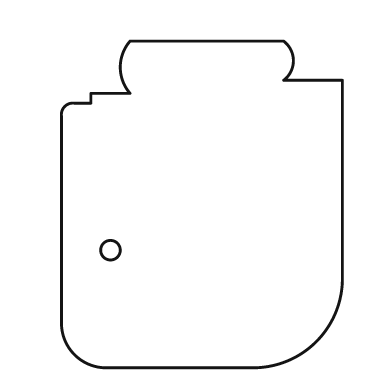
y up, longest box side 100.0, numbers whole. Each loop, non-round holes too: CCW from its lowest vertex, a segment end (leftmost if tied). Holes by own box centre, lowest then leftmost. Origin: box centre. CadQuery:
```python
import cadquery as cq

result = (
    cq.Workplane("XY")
    .moveTo(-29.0, -50.0)
    .lineTo(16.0, -50.0)
    .threePointArc((35.0, -42.0), (43.0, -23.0))
    .lineTo(43.0, 38.0)
    .lineTo(25.0, 38.0)
    .threePointArc((28.0, 44.0), (25.0, 50.0))
    .lineTo(-22.0, 50.0)
    .threePointArc((-25.0, 42.0), (-22.0, 34.0))
    .lineTo(-34.0, 34.0)
    .lineTo(-34.0, 31.0)
    .lineTo(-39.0, 31.0)
    .threePointArc((-42.0, 30.0), (-43.0, 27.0))
    .lineTo(-43.0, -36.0)
    .threePointArc((-39.0, -46.0), (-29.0, -50.0))
    .close()
    .moveTo(-28.0, -14.0)
    .circle(3.0)
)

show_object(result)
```